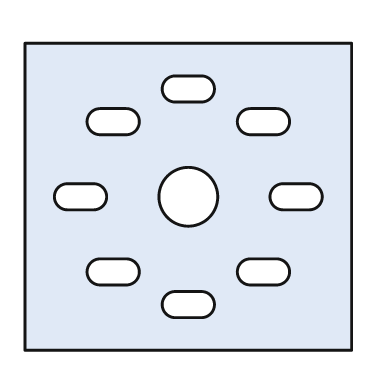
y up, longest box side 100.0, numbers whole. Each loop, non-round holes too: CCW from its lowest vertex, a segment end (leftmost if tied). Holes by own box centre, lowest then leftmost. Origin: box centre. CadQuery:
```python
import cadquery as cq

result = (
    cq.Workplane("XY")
    .moveTo(-50.0, -47.0)
    .lineTo(50.0, -47.0)
    .lineTo(50.0, 47.0)
    .lineTo(-50.0, 47.0)
    .close()
    .moveTo(-4.0, -37.0)
    .lineTo(4.0, -37.0)
    .threePointArc((8.0, -33.0), (4.0, -29.0))
    .lineTo(-4.0, -29.0)
    .threePointArc((-8.0, -33.0), (-4.0, -37.0))
    .close()
    .moveTo(-27.0, -27.0)
    .lineTo(-19.0, -27.0)
    .threePointArc((-15.0, -23.0), (-19.0, -19.0))
    .lineTo(-27.0, -19.0)
    .threePointArc((-31.0, -23.0), (-27.0, -27.0))
    .close()
    .moveTo(19.0, -27.0)
    .lineTo(27.0, -27.0)
    .threePointArc((31.0, -23.0), (27.0, -19.0))
    .lineTo(19.0, -19.0)
    .threePointArc((15.0, -23.0), (19.0, -27.0))
    .close()
    .moveTo(-37.0, -4.0)
    .lineTo(-29.0, -4.0)
    .threePointArc((-25.0, 0.0), (-29.0, 4.0))
    .lineTo(-37.0, 4.0)
    .threePointArc((-41.0, 0.0), (-37.0, -4.0))
    .close()
    .moveTo(0.0, 0.0)
    .circle(9.0)
    .moveTo(29.0, -4.0)
    .lineTo(37.0, -4.0)
    .threePointArc((41.0, 0.0), (37.0, 4.0))
    .lineTo(29.0, 4.0)
    .threePointArc((25.0, 0.0), (29.0, -4.0))
    .close()
    .moveTo(-27.0, 19.0)
    .lineTo(-19.0, 19.0)
    .threePointArc((-15.0, 23.0), (-19.0, 27.0))
    .lineTo(-27.0, 27.0)
    .threePointArc((-31.0, 23.0), (-27.0, 19.0))
    .close()
    .moveTo(19.0, 19.0)
    .lineTo(27.0, 19.0)
    .threePointArc((31.0, 23.0), (27.0, 27.0))
    .lineTo(19.0, 27.0)
    .threePointArc((15.0, 23.0), (19.0, 19.0))
    .close()
    .moveTo(-4.0, 29.0)
    .lineTo(4.0, 29.0)
    .threePointArc((8.0, 33.0), (4.0, 37.0))
    .lineTo(-4.0, 37.0)
    .threePointArc((-8.0, 33.0), (-4.0, 29.0))
    .close()
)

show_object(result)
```